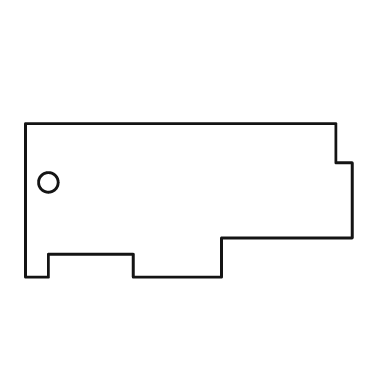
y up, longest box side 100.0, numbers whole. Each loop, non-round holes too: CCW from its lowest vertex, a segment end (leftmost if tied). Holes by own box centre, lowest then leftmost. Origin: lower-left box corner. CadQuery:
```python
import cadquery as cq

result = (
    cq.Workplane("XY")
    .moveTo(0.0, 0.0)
    .lineTo(7.0, 0.0)
    .lineTo(7.0, 7.0)
    .lineTo(33.0, 7.0)
    .lineTo(33.0, 0.0)
    .lineTo(60.0, 0.0)
    .lineTo(60.0, 12.0)
    .lineTo(100.0, 12.0)
    .lineTo(100.0, 35.0)
    .lineTo(95.0, 35.0)
    .lineTo(95.0, 47.0)
    .lineTo(0.0, 47.0)
    .close()
    .moveTo(7.0, 29.0)
    .circle(3.0)
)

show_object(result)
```